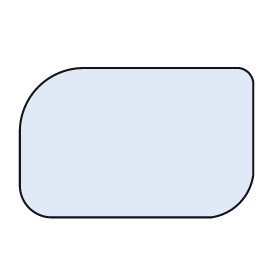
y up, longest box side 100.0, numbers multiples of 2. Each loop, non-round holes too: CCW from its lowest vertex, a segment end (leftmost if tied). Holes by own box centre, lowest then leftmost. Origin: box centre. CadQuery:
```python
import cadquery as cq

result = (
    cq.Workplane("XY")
    .moveTo(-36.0, -32.0)
    .lineTo(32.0, -32.0)
    .threePointArc((44.0, -26.0), (50.0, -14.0))
    .lineTo(50.0, 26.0)
    .threePointArc((48.0, 30.0), (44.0, 32.0))
    .lineTo(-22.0, 32.0)
    .threePointArc((-42.0, 24.0), (-50.0, 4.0))
    .lineTo(-50.0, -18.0)
    .threePointArc((-46.0, -28.0), (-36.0, -32.0))
    .close()
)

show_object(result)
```